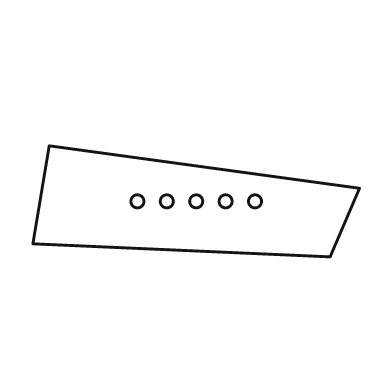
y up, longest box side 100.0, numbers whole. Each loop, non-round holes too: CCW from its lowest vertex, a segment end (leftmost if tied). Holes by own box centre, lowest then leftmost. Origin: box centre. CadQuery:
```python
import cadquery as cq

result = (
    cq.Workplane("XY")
    .moveTo(41.0, -17.0)
    .lineTo(50.0, 4.0)
    .lineTo(-45.0, 17.0)
    .lineTo(-50.0, -13.0)
    .close()
    .moveTo(-18.0, 0.0)
    .circle(2.0)
    .moveTo(-9.0, 0.0)
    .circle(2.0)
    .moveTo(0.0, 0.0)
    .circle(2.0)
    .moveTo(9.0, 0.0)
    .circle(2.0)
    .moveTo(18.0, 0.0)
    .circle(2.0)
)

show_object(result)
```